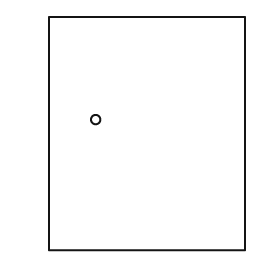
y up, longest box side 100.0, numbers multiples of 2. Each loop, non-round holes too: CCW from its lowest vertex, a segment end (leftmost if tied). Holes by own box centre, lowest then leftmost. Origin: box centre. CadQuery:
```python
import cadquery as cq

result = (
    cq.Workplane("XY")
    .moveTo(-42.0, -50.0)
    .lineTo(42.0, -50.0)
    .lineTo(42.0, 50.0)
    .lineTo(-42.0, 50.0)
    .close()
    .moveTo(-22.0, 6.0)
    .circle(2.0)
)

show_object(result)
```